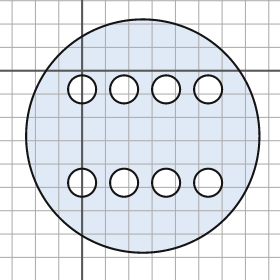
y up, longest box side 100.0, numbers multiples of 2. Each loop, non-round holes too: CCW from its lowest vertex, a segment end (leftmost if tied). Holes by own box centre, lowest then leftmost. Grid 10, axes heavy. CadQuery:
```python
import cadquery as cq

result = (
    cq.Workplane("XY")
    .moveTo(26.0, -28.0)
    .circle(50.0)
    .moveTo(0.0, -48.0)
    .circle(6.0)
    .moveTo(18.0, -48.0)
    .circle(6.0)
    .moveTo(36.0, -48.0)
    .circle(6.0)
    .moveTo(54.0, -48.0)
    .circle(6.0)
    .moveTo(0.0, -8.0)
    .circle(6.0)
    .moveTo(18.0, -8.0)
    .circle(6.0)
    .moveTo(36.0, -8.0)
    .circle(6.0)
    .moveTo(54.0, -8.0)
    .circle(6.0)
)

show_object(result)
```